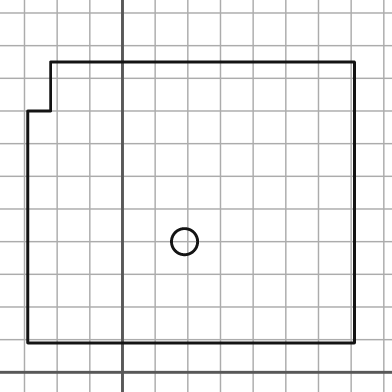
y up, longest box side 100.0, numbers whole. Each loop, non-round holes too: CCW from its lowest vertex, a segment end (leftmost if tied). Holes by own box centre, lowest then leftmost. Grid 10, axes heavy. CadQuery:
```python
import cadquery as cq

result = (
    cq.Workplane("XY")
    .moveTo(-29.0, 9.0)
    .lineTo(71.0, 9.0)
    .lineTo(71.0, 95.0)
    .lineTo(-22.0, 95.0)
    .lineTo(-22.0, 80.0)
    .lineTo(-29.0, 80.0)
    .close()
    .moveTo(19.0, 40.0)
    .circle(4.0)
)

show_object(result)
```